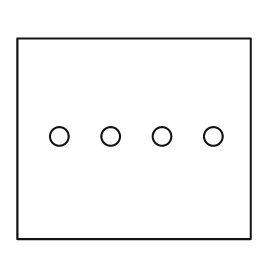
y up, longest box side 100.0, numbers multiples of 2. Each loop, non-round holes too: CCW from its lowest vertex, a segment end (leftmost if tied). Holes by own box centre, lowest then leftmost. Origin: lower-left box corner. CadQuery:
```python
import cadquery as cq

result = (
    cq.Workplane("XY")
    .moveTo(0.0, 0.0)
    .lineTo(100.0, 0.0)
    .lineTo(100.0, 86.0)
    .lineTo(0.0, 86.0)
    .close()
    .moveTo(18.0, 44.0)
    .circle(4.0)
    .moveTo(40.0, 44.0)
    .circle(4.0)
    .moveTo(62.0, 44.0)
    .circle(4.0)
    .moveTo(84.0, 44.0)
    .circle(4.0)
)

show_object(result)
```